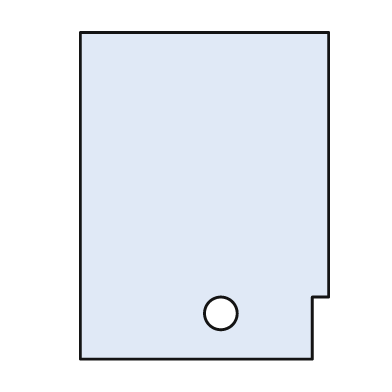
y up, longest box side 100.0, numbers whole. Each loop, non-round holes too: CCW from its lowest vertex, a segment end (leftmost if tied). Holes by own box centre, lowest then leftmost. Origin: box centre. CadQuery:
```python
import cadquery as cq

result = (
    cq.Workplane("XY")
    .moveTo(-38.0, -50.0)
    .lineTo(33.0, -50.0)
    .lineTo(33.0, -31.0)
    .lineTo(38.0, -31.0)
    .lineTo(38.0, 50.0)
    .lineTo(-38.0, 50.0)
    .close()
    .moveTo(5.0, -36.0)
    .circle(5.0)
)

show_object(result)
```